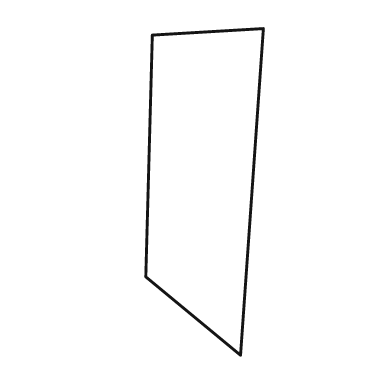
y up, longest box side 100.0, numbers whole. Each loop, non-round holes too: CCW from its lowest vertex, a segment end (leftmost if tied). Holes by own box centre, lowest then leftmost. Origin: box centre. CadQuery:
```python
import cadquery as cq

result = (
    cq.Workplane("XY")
    .moveTo(11.0, -50.0)
    .lineTo(18.0, 50.0)
    .lineTo(-16.0, 48.0)
    .lineTo(-18.0, -26.0)
    .close()
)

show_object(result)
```